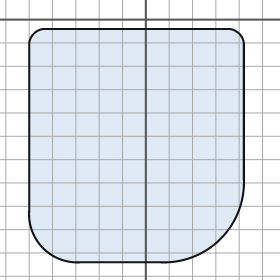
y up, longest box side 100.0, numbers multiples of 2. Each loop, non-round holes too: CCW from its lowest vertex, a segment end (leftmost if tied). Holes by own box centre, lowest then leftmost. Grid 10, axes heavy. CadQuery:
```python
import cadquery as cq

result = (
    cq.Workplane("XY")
    .moveTo(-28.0, -104.0)
    .lineTo(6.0, -104.0)
    .threePointArc((32.0, -94.0), (42.0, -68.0))
    .lineTo(42.0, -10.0)
    .threePointArc((40.0, -6.0), (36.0, -4.0))
    .lineTo(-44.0, -4.0)
    .threePointArc((-48.0, -6.0), (-50.0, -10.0))
    .lineTo(-50.0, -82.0)
    .threePointArc((-44.0, -98.0), (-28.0, -104.0))
    .close()
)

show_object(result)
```